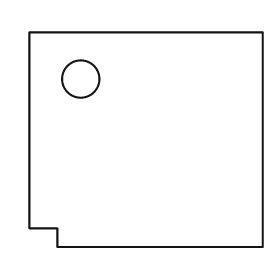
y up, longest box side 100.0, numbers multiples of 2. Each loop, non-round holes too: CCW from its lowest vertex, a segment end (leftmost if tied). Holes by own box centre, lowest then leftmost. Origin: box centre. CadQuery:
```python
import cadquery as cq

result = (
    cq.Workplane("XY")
    .moveTo(-38.0, -46.0)
    .lineTo(50.0, -46.0)
    .lineTo(50.0, 46.0)
    .lineTo(-50.0, 46.0)
    .lineTo(-50.0, -38.0)
    .lineTo(-38.0, -38.0)
    .close()
    .moveTo(-28.0, 26.0)
    .circle(8.0)
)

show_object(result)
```